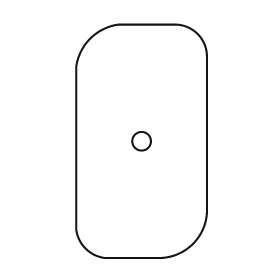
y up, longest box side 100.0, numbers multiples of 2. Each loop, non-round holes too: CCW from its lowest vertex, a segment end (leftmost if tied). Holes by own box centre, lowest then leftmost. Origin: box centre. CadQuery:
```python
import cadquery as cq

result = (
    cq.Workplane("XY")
    .moveTo(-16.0, -50.0)
    .lineTo(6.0, -50.0)
    .threePointArc((22.0, -44.0), (28.0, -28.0))
    .lineTo(28.0, 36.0)
    .threePointArc((24.0, 46.0), (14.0, 50.0))
    .lineTo(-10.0, 50.0)
    .threePointArc((-22.0, 44.0), (-28.0, 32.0))
    .lineTo(-28.0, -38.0)
    .threePointArc((-24.0, -46.0), (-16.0, -50.0))
    .close()
    .moveTo(0.0, 0.0)
    .circle(4.0)
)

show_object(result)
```